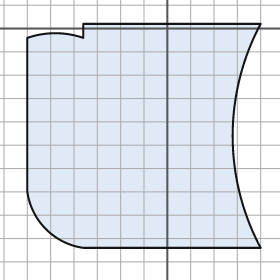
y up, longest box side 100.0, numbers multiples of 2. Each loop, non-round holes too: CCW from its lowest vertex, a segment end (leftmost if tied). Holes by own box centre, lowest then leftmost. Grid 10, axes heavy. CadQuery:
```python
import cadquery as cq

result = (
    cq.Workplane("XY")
    .moveTo(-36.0, -94.0)
    .lineTo(40.0, -94.0)
    .threePointArc((28.0, -46.0), (40.0, 2.0))
    .lineTo(-36.0, 2.0)
    .lineTo(-36.0, -4.0)
    .threePointArc((-48.0, -2.0), (-60.0, -4.0))
    .lineTo(-60.0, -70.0)
    .threePointArc((-52.0, -86.0), (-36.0, -94.0))
    .close()
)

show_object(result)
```